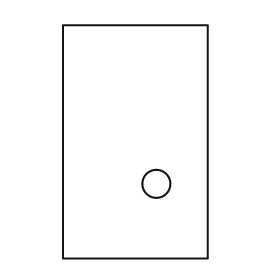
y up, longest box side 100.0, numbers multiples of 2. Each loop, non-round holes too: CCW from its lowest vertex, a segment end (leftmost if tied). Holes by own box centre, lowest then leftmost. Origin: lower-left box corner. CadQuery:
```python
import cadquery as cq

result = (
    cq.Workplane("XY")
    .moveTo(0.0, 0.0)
    .lineTo(62.0, 0.0)
    .lineTo(62.0, 100.0)
    .lineTo(0.0, 100.0)
    .close()
    .moveTo(40.0, 32.0)
    .circle(6.0)
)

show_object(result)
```